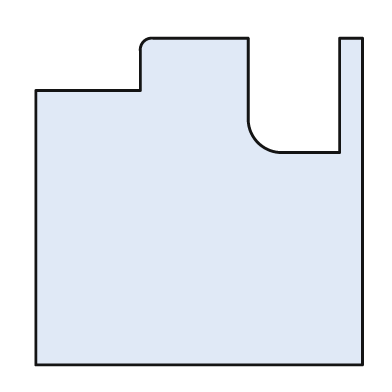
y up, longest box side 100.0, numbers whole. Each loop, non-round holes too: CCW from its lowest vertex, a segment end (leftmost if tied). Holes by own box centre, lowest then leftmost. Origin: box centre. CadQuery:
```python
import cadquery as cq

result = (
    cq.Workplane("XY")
    .moveTo(-50.0, -50.0)
    .lineTo(50.0, -50.0)
    .lineTo(50.0, 50.0)
    .lineTo(43.0, 50.0)
    .lineTo(43.0, 15.0)
    .lineTo(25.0, 15.0)
    .threePointArc((18.0, 18.0), (15.0, 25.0))
    .lineTo(15.0, 50.0)
    .lineTo(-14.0, 50.0)
    .threePointArc((-17.0, 49.0), (-18.0, 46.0))
    .lineTo(-18.0, 34.0)
    .lineTo(-50.0, 34.0)
    .close()
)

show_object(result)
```